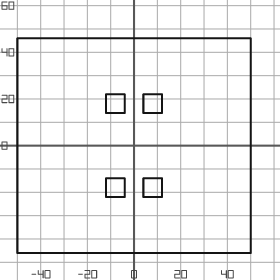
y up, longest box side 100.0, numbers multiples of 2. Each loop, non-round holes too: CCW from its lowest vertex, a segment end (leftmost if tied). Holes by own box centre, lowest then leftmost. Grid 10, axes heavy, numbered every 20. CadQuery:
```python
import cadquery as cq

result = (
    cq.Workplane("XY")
    .moveTo(-50.0, -46.0)
    .lineTo(50.0, -46.0)
    .lineTo(50.0, 46.0)
    .lineTo(-50.0, 46.0)
    .close()
    .moveTo(-12.0, -22.0)
    .lineTo(-4.0, -22.0)
    .lineTo(-4.0, -14.0)
    .lineTo(-12.0, -14.0)
    .close()
    .moveTo(4.0, -22.0)
    .lineTo(12.0, -22.0)
    .lineTo(12.0, -14.0)
    .lineTo(4.0, -14.0)
    .close()
    .moveTo(-12.0, 14.0)
    .lineTo(-4.0, 14.0)
    .lineTo(-4.0, 22.0)
    .lineTo(-12.0, 22.0)
    .close()
    .moveTo(4.0, 14.0)
    .lineTo(12.0, 14.0)
    .lineTo(12.0, 22.0)
    .lineTo(4.0, 22.0)
    .close()
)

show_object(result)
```